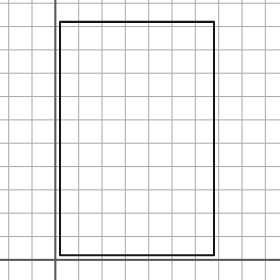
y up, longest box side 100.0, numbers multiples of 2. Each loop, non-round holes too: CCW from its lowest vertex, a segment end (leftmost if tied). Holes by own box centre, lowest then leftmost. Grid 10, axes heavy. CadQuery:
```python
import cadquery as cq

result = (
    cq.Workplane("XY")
    .moveTo(2.0, 2.0)
    .lineTo(68.0, 2.0)
    .lineTo(68.0, 102.0)
    .lineTo(2.0, 102.0)
    .close()
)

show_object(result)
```